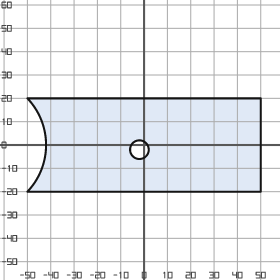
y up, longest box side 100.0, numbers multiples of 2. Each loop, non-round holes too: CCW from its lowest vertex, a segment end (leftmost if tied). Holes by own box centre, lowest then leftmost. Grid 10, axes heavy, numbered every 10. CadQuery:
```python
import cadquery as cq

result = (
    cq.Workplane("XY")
    .moveTo(-50.0, -20.0)
    .lineTo(50.0, -20.0)
    .lineTo(50.0, 20.0)
    .lineTo(-50.0, 20.0)
    .threePointArc((-42.0, 0.0), (-50.0, -20.0))
    .close()
    .moveTo(-2.0, -2.0)
    .circle(4.0)
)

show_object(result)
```